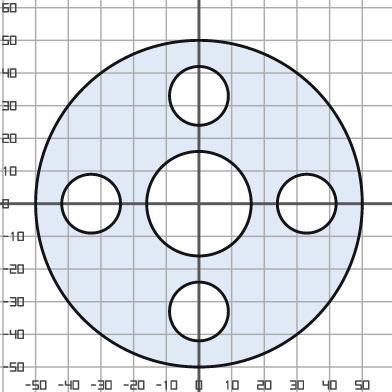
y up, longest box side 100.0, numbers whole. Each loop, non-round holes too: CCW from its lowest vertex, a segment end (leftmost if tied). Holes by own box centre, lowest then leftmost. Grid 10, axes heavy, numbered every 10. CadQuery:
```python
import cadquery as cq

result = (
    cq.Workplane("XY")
    .moveTo(0.0, 0.0)
    .circle(50.0)
    .moveTo(0.0, -33.0)
    .circle(9.0)
    .moveTo(-33.0, 0.0)
    .circle(9.0)
    .moveTo(0.0, 0.0)
    .circle(16.0)
    .moveTo(33.0, 0.0)
    .circle(9.0)
    .moveTo(0.0, 33.0)
    .circle(9.0)
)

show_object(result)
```